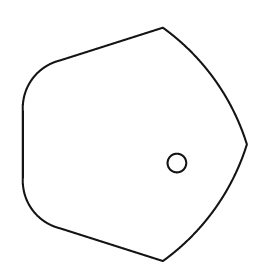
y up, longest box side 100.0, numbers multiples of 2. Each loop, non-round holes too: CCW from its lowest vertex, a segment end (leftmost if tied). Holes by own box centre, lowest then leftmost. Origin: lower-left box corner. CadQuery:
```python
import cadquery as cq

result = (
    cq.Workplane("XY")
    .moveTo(60.0, 0.0)
    .threePointArc((82.0, 22.0), (96.0, 50.0))
    .threePointArc((82.0, 78.0), (60.0, 100.0))
    .lineTo(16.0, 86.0)
    .threePointArc((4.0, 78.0), (0.0, 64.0))
    .lineTo(0.0, 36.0)
    .threePointArc((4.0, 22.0), (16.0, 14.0))
    .close()
    .moveTo(66.0, 42.0)
    .circle(4.0)
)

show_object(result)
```